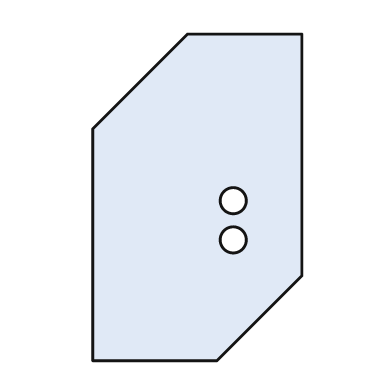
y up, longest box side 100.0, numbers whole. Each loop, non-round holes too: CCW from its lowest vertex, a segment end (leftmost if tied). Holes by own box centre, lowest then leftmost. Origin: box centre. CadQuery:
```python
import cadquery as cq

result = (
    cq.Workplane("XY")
    .moveTo(-32.0, -50.0)
    .lineTo(6.0, -50.0)
    .lineTo(32.0, -24.0)
    .lineTo(32.0, 50.0)
    .lineTo(-3.0, 50.0)
    .lineTo(-32.0, 21.0)
    .close()
    .moveTo(11.0, -13.0)
    .circle(4.0)
    .moveTo(11.0, -1.0)
    .circle(4.0)
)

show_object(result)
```